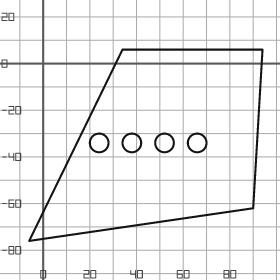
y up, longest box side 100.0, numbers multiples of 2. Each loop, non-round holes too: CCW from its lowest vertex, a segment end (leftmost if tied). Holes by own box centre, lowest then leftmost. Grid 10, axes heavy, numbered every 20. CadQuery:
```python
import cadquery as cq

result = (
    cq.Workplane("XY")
    .moveTo(-6.0, -76.0)
    .lineTo(90.0, -62.0)
    .lineTo(94.0, 6.0)
    .lineTo(34.0, 6.0)
    .close()
    .moveTo(24.0, -34.0)
    .circle(4.0)
    .moveTo(38.0, -34.0)
    .circle(4.0)
    .moveTo(52.0, -34.0)
    .circle(4.0)
    .moveTo(66.0, -34.0)
    .circle(4.0)
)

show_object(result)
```